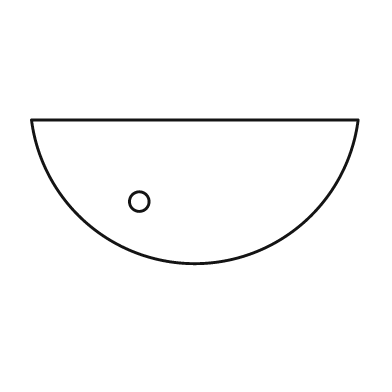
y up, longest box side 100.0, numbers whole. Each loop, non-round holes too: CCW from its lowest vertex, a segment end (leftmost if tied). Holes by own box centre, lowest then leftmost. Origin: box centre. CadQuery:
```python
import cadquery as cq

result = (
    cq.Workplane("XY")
    .moveTo(-50.0, 22.0)
    .threePointArc((0.0, -22.0), (50.0, 22.0))
    .close()
    .moveTo(-17.0, -3.0)
    .circle(3.0)
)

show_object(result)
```